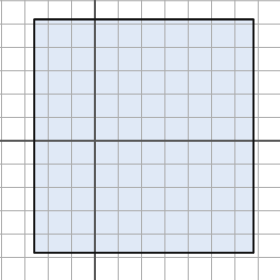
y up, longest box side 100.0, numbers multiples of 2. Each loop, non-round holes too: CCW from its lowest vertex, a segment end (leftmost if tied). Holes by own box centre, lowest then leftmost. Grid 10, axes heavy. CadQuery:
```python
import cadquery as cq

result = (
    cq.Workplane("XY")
    .moveTo(-26.0, -48.0)
    .lineTo(68.0, -48.0)
    .lineTo(68.0, 52.0)
    .lineTo(-26.0, 52.0)
    .close()
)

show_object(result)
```